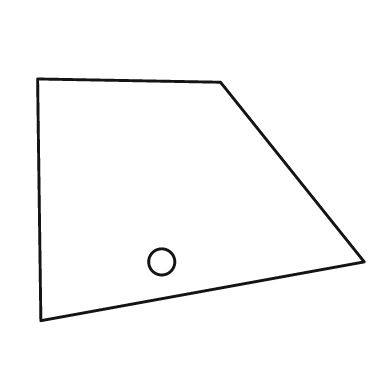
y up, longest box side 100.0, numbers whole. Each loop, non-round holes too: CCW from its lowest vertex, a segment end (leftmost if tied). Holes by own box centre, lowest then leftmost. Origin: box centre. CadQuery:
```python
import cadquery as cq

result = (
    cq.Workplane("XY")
    .moveTo(-49.0, -37.0)
    .lineTo(50.0, -19.0)
    .lineTo(6.0, 36.0)
    .lineTo(-50.0, 37.0)
    .close()
    .moveTo(-12.0, -19.0)
    .circle(4.0)
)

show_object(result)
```